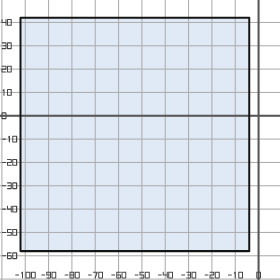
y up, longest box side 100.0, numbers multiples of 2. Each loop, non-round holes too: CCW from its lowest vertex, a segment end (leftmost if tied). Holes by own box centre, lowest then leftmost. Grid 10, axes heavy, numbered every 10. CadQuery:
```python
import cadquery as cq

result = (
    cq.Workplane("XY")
    .moveTo(-102.0, -58.0)
    .lineTo(-4.0, -58.0)
    .lineTo(-4.0, 42.0)
    .lineTo(-102.0, 42.0)
    .close()
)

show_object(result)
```